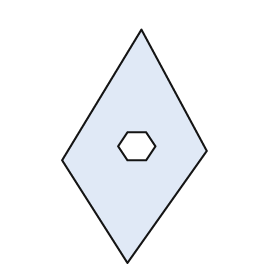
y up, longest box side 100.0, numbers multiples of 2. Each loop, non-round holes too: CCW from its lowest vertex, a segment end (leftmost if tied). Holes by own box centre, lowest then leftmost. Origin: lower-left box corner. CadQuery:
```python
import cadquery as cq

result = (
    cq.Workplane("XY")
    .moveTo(28.0, 0.0)
    .lineTo(62.0, 48.0)
    .lineTo(34.0, 100.0)
    .lineTo(0.0, 44.0)
    .close()
    .moveTo(28.0, 44.0)
    .lineTo(36.0, 44.0)
    .lineTo(40.0, 50.0)
    .lineTo(36.0, 56.0)
    .lineTo(28.0, 56.0)
    .lineTo(24.0, 50.0)
    .close()
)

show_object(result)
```